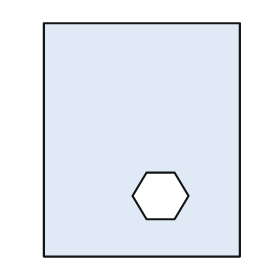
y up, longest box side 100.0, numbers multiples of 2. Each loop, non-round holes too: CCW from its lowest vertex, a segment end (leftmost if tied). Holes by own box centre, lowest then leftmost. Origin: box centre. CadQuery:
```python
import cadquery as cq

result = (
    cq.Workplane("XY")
    .moveTo(-42.0, -50.0)
    .lineTo(42.0, -50.0)
    .lineTo(42.0, 50.0)
    .lineTo(-42.0, 50.0)
    .close()
    .moveTo(2.0, -34.0)
    .lineTo(14.0, -34.0)
    .lineTo(20.0, -24.0)
    .lineTo(14.0, -14.0)
    .lineTo(2.0, -14.0)
    .lineTo(-4.0, -24.0)
    .close()
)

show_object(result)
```